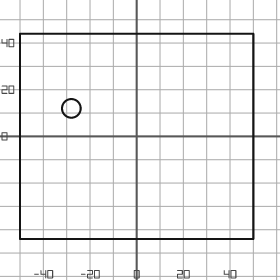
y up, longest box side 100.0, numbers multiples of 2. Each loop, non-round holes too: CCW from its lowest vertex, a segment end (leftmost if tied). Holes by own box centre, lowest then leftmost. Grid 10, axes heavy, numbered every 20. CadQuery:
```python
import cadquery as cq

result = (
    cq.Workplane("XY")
    .moveTo(-50.0, -44.0)
    .lineTo(50.0, -44.0)
    .lineTo(50.0, 44.0)
    .lineTo(-50.0, 44.0)
    .close()
    .moveTo(-28.0, 12.0)
    .circle(4.0)
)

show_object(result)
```